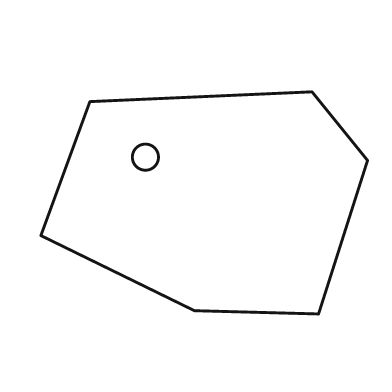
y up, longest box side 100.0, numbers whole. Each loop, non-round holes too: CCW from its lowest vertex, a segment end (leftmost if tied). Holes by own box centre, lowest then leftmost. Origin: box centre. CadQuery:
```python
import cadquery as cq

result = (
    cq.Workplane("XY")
    .moveTo(35.0, -34.0)
    .lineTo(50.0, 13.0)
    .lineTo(33.0, 34.0)
    .lineTo(-35.0, 31.0)
    .lineTo(-50.0, -10.0)
    .lineTo(-3.0, -33.0)
    .close()
    .moveTo(-18.0, 14.0)
    .circle(4.0)
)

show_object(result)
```